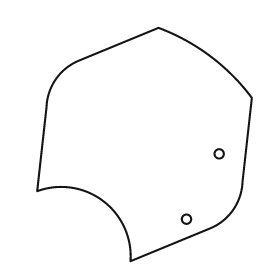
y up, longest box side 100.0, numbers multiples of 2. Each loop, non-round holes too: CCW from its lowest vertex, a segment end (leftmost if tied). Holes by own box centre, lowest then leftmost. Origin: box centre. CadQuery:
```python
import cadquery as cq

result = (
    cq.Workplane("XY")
    .moveTo(-6.0, -50.0)
    .lineTo(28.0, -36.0)
    .threePointArc((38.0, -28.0), (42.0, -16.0))
    .lineTo(46.0, 20.0)
    .threePointArc((28.0, 38.0), (6.0, 50.0))
    .lineTo(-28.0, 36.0)
    .threePointArc((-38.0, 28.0), (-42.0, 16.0))
    .lineTo(-46.0, -20.0)
    .threePointArc((-18.0, -24.0), (-6.0, -50.0))
    .close()
    .moveTo(18.0, -32.0)
    .circle(2.0)
    .moveTo(32.0, -4.0)
    .circle(2.0)
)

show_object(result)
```